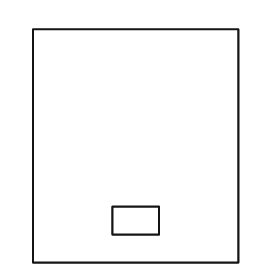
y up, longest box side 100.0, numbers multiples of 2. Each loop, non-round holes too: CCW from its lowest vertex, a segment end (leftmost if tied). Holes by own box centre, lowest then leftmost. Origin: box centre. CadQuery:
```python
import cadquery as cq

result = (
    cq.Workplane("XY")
    .moveTo(-44.0, -50.0)
    .lineTo(44.0, -50.0)
    .lineTo(44.0, 50.0)
    .lineTo(-44.0, 50.0)
    .close()
    .moveTo(-10.0, -38.0)
    .lineTo(10.0, -38.0)
    .lineTo(10.0, -26.0)
    .lineTo(-10.0, -26.0)
    .close()
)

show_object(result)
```